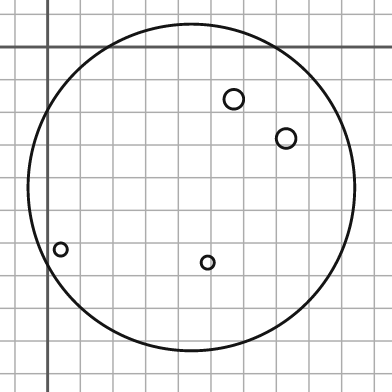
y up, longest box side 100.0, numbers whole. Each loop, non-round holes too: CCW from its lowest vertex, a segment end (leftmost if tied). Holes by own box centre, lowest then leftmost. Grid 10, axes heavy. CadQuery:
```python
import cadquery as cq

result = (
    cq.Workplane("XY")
    .moveTo(44.0, -43.0)
    .circle(50.0)
    .moveTo(49.0, -66.0)
    .circle(2.0)
    .moveTo(4.0, -62.0)
    .circle(2.0)
    .moveTo(73.0, -28.0)
    .circle(3.0)
    .moveTo(57.0, -16.0)
    .circle(3.0)
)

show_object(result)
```